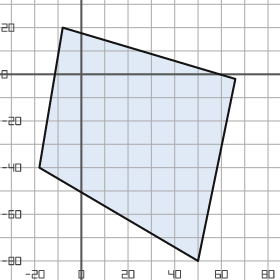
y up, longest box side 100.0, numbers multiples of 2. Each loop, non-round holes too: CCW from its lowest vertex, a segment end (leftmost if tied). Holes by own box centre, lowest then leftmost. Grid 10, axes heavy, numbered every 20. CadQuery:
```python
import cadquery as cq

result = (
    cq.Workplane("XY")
    .moveTo(50.0, -80.0)
    .lineTo(66.0, -2.0)
    .lineTo(-8.0, 20.0)
    .lineTo(-18.0, -40.0)
    .close()
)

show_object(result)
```